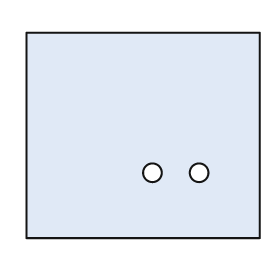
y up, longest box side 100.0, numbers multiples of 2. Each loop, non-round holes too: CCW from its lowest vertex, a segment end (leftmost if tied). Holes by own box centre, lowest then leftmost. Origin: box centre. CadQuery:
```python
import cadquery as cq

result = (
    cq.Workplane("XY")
    .moveTo(-50.0, -44.0)
    .lineTo(50.0, -44.0)
    .lineTo(50.0, 44.0)
    .lineTo(-50.0, 44.0)
    .close()
    .moveTo(4.0, -16.0)
    .circle(4.0)
    .moveTo(24.0, -16.0)
    .circle(4.0)
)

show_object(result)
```